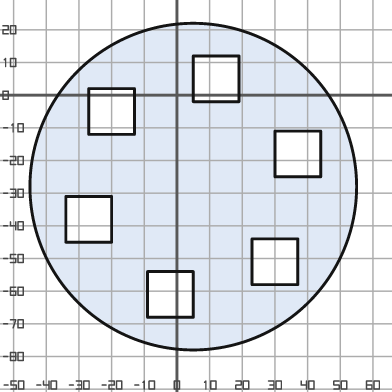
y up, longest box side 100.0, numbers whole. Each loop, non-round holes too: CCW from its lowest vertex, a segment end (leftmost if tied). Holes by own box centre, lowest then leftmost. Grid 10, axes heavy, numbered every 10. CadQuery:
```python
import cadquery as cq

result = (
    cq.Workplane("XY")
    .moveTo(5.0, -28.0)
    .circle(50.0)
    .moveTo(-9.0, -68.0)
    .lineTo(5.0, -68.0)
    .lineTo(5.0, -54.0)
    .lineTo(-9.0, -54.0)
    .close()
    .moveTo(23.0, -58.0)
    .lineTo(37.0, -58.0)
    .lineTo(37.0, -44.0)
    .lineTo(23.0, -44.0)
    .close()
    .moveTo(-34.0, -45.0)
    .lineTo(-20.0, -45.0)
    .lineTo(-20.0, -31.0)
    .lineTo(-34.0, -31.0)
    .close()
    .moveTo(30.0, -25.0)
    .lineTo(44.0, -25.0)
    .lineTo(44.0, -11.0)
    .lineTo(30.0, -11.0)
    .close()
    .moveTo(-27.0, -12.0)
    .lineTo(-13.0, -12.0)
    .lineTo(-13.0, 2.0)
    .lineTo(-27.0, 2.0)
    .close()
    .moveTo(5.0, -2.0)
    .lineTo(19.0, -2.0)
    .lineTo(19.0, 12.0)
    .lineTo(5.0, 12.0)
    .close()
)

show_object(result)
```